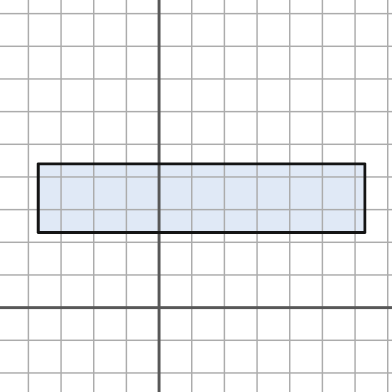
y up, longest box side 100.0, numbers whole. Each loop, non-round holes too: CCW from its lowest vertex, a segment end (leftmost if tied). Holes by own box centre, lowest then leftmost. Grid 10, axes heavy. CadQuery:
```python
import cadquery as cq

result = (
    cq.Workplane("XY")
    .moveTo(-37.0, 23.0)
    .lineTo(63.0, 23.0)
    .lineTo(63.0, 44.0)
    .lineTo(-37.0, 44.0)
    .close()
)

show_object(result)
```